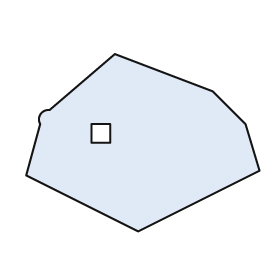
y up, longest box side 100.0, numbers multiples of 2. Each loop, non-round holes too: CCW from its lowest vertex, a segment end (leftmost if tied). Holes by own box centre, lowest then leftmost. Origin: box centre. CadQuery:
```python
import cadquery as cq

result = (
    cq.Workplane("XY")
    .moveTo(-2.0, -38.0)
    .lineTo(50.0, -12.0)
    .lineTo(44.0, 8.0)
    .lineTo(30.0, 22.0)
    .lineTo(-12.0, 38.0)
    .lineTo(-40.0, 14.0)
    .threePointArc((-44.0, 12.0), (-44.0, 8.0))
    .lineTo(-50.0, -14.0)
    .close()
    .moveTo(-22.0, 0.0)
    .lineTo(-14.0, 0.0)
    .lineTo(-14.0, 8.0)
    .lineTo(-22.0, 8.0)
    .close()
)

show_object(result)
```